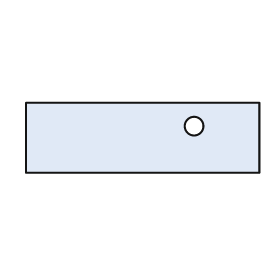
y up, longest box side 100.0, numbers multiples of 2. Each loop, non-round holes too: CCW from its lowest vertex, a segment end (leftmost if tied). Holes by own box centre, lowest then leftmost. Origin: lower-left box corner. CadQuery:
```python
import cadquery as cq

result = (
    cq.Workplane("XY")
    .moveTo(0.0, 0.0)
    .lineTo(100.0, 0.0)
    .lineTo(100.0, 30.0)
    .lineTo(0.0, 30.0)
    .close()
    .moveTo(72.0, 20.0)
    .circle(4.0)
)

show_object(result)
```